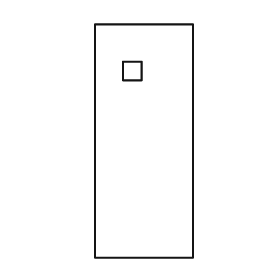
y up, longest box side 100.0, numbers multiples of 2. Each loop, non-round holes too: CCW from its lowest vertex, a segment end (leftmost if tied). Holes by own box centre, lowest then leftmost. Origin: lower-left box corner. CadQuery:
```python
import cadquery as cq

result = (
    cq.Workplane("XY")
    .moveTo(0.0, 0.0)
    .lineTo(42.0, 0.0)
    .lineTo(42.0, 100.0)
    .lineTo(0.0, 100.0)
    .close()
    .moveTo(12.0, 76.0)
    .lineTo(20.0, 76.0)
    .lineTo(20.0, 84.0)
    .lineTo(12.0, 84.0)
    .close()
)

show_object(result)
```